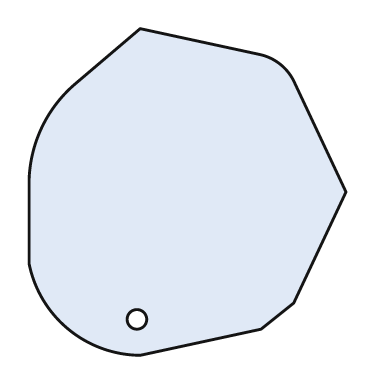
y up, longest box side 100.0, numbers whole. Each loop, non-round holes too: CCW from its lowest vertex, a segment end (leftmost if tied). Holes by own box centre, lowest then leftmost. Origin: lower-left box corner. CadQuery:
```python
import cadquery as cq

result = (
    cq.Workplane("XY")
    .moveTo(34.0, 0.0)
    .lineTo(71.0, 8.0)
    .lineTo(81.0, 16.0)
    .lineTo(97.0, 50.0)
    .lineTo(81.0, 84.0)
    .threePointArc((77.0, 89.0), (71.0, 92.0))
    .lineTo(34.0, 100.0)
    .lineTo(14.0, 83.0)
    .threePointArc((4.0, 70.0), (0.0, 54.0))
    .lineTo(0.0, 28.0)
    .threePointArc((12.0, 8.0), (34.0, 0.0))
    .close()
    .moveTo(33.0, 11.0)
    .circle(3.0)
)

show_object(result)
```